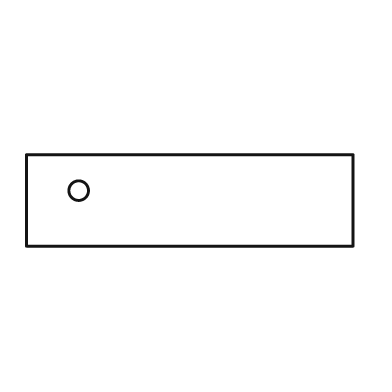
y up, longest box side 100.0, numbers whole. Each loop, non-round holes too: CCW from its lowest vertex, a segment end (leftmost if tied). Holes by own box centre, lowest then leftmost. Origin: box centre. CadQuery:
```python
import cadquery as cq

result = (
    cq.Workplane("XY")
    .moveTo(-50.0, -14.0)
    .lineTo(50.0, -14.0)
    .lineTo(50.0, 14.0)
    .lineTo(-50.0, 14.0)
    .close()
    .moveTo(-34.0, 3.0)
    .circle(3.0)
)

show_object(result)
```